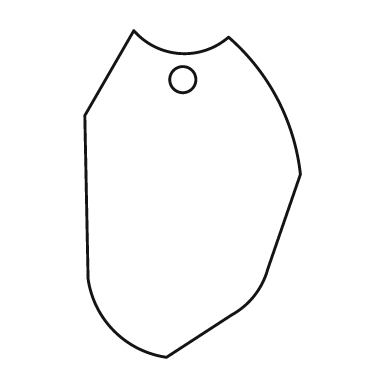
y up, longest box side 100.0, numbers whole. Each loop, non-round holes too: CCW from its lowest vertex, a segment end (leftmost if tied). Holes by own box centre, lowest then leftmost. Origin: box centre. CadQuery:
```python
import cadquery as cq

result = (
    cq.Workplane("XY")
    .moveTo(-8.0, -50.0)
    .lineTo(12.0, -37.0)
    .threePointArc((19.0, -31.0), (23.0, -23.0))
    .lineTo(33.0, 6.0)
    .threePointArc((26.0, 29.0), (11.0, 48.0))
    .threePointArc((-4.0, 43.0), (-18.0, 50.0))
    .lineTo(-33.0, 24.0)
    .lineTo(-32.0, -26.0)
    .threePointArc((-24.0, -42.0), (-8.0, -50.0))
    .close()
    .moveTo(-3.0, 35.0)
    .circle(4.0)
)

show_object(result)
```